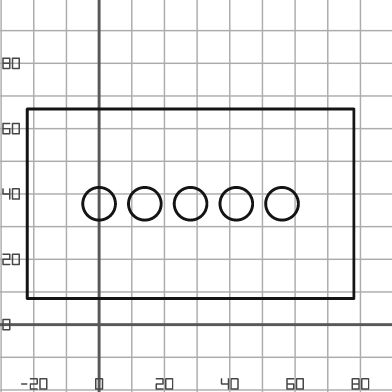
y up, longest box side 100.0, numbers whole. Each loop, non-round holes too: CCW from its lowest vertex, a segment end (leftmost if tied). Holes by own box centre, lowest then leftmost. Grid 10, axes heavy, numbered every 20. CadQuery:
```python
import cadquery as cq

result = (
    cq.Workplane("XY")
    .moveTo(-22.0, 8.0)
    .lineTo(78.0, 8.0)
    .lineTo(78.0, 66.0)
    .lineTo(-22.0, 66.0)
    .close()
    .moveTo(0.0, 37.0)
    .circle(5.0)
    .moveTo(14.0, 37.0)
    .circle(5.0)
    .moveTo(28.0, 37.0)
    .circle(5.0)
    .moveTo(42.0, 37.0)
    .circle(5.0)
    .moveTo(56.0, 37.0)
    .circle(5.0)
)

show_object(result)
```